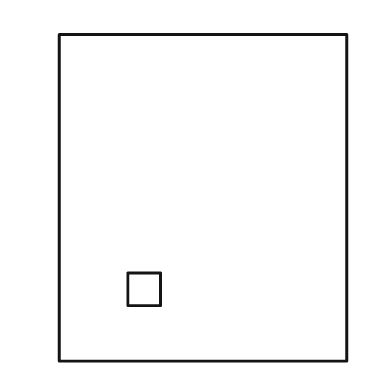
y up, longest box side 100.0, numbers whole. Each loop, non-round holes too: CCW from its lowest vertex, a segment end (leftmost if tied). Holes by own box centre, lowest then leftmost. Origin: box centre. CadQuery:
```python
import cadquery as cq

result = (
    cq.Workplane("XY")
    .moveTo(-44.0, -50.0)
    .lineTo(44.0, -50.0)
    .lineTo(44.0, 50.0)
    .lineTo(-44.0, 50.0)
    .close()
    .moveTo(-23.0, -33.0)
    .lineTo(-13.0, -33.0)
    .lineTo(-13.0, -23.0)
    .lineTo(-23.0, -23.0)
    .close()
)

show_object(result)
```